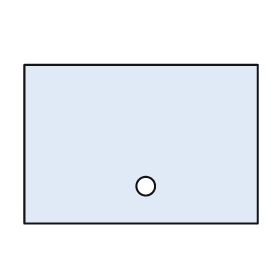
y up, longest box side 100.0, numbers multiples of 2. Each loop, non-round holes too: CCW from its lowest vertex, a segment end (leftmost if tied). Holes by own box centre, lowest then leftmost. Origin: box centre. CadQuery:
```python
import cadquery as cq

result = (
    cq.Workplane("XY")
    .moveTo(-50.0, -34.0)
    .lineTo(50.0, -34.0)
    .lineTo(50.0, 34.0)
    .lineTo(-50.0, 34.0)
    .close()
    .moveTo(2.0, -18.0)
    .circle(4.0)
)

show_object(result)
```